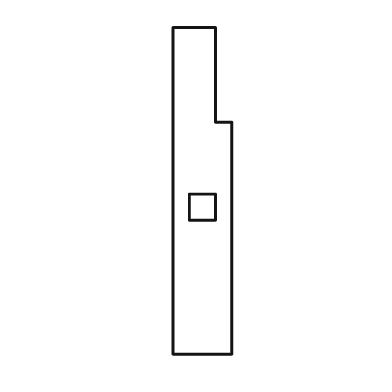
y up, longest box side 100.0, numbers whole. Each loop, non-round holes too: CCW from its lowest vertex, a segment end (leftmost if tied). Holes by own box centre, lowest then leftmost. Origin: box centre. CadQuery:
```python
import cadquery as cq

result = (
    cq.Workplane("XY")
    .moveTo(-9.0, -50.0)
    .lineTo(9.0, -50.0)
    .lineTo(9.0, 21.0)
    .lineTo(4.0, 21.0)
    .lineTo(4.0, 50.0)
    .lineTo(-9.0, 50.0)
    .close()
    .moveTo(-4.0, -9.0)
    .lineTo(4.0, -9.0)
    .lineTo(4.0, -1.0)
    .lineTo(-4.0, -1.0)
    .close()
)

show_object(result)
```